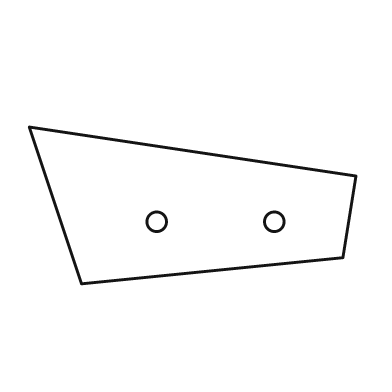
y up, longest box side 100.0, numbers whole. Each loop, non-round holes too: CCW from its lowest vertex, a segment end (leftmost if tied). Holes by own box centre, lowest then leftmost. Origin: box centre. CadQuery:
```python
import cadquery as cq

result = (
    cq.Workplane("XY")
    .moveTo(-34.0, -24.0)
    .lineTo(46.0, -16.0)
    .lineTo(50.0, 9.0)
    .lineTo(-50.0, 24.0)
    .close()
    .moveTo(-11.0, -5.0)
    .circle(3.0)
    .moveTo(25.0, -5.0)
    .circle(3.0)
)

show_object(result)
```